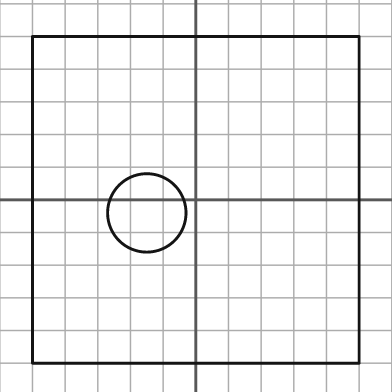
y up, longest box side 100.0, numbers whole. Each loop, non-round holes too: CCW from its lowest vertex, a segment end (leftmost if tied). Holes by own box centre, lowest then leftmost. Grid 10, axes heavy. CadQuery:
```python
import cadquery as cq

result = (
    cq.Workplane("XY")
    .moveTo(-50.0, -50.0)
    .lineTo(50.0, -50.0)
    .lineTo(50.0, 50.0)
    .lineTo(-50.0, 50.0)
    .close()
    .moveTo(-15.0, -4.0)
    .circle(12.0)
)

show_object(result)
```